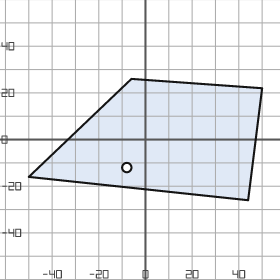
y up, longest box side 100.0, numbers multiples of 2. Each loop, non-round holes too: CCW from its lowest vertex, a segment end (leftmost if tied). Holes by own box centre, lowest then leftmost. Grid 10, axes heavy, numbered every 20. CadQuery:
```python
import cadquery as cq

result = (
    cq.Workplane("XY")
    .moveTo(44.0, -26.0)
    .lineTo(50.0, 22.0)
    .lineTo(-6.0, 26.0)
    .lineTo(-50.0, -16.0)
    .close()
    .moveTo(-8.0, -12.0)
    .circle(2.0)
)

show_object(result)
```